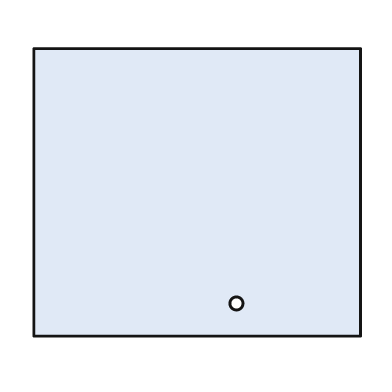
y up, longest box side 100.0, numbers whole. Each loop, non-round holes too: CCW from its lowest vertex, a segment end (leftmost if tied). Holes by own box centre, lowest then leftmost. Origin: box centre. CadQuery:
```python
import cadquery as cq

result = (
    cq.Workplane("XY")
    .moveTo(-50.0, -44.0)
    .lineTo(50.0, -44.0)
    .lineTo(50.0, 44.0)
    .lineTo(-50.0, 44.0)
    .close()
    .moveTo(12.0, -34.0)
    .circle(2.0)
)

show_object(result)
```